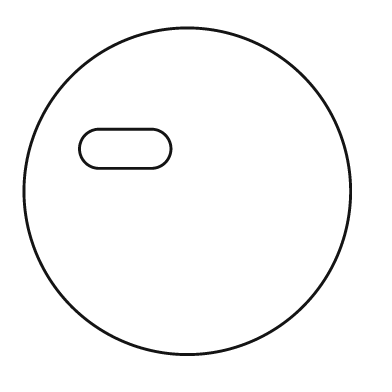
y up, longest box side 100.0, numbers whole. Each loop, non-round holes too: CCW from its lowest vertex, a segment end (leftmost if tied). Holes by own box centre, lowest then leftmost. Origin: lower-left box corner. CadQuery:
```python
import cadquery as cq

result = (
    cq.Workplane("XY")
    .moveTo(50.0, 50.0)
    .circle(50.0)
    .moveTo(23.0, 57.0)
    .lineTo(39.0, 57.0)
    .threePointArc((45.0, 63.0), (39.0, 69.0))
    .lineTo(23.0, 69.0)
    .threePointArc((17.0, 63.0), (23.0, 57.0))
    .close()
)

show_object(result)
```